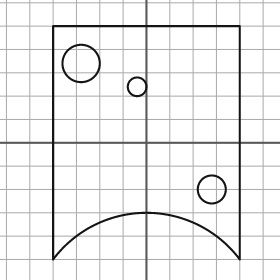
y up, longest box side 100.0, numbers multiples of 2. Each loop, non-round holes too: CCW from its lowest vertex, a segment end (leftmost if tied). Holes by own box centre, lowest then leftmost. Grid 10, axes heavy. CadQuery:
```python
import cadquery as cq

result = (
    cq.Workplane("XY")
    .moveTo(-40.0, -50.0)
    .threePointArc((0.0, -30.0), (40.0, -50.0))
    .lineTo(40.0, 50.0)
    .lineTo(-40.0, 50.0)
    .close()
    .moveTo(28.0, -20.0)
    .circle(6.0)
    .moveTo(-4.0, 24.0)
    .circle(4.0)
    .moveTo(-28.0, 34.0)
    .circle(8.0)
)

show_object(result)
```